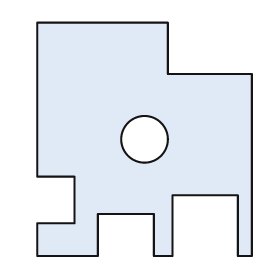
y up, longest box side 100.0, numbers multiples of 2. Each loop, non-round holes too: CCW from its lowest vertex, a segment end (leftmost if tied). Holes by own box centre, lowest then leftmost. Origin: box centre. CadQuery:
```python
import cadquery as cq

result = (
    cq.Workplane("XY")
    .moveTo(-46.0, -50.0)
    .lineTo(-20.0, -50.0)
    .lineTo(-20.0, -32.0)
    .lineTo(4.0, -32.0)
    .lineTo(4.0, -50.0)
    .lineTo(12.0, -50.0)
    .lineTo(12.0, -24.0)
    .lineTo(40.0, -24.0)
    .lineTo(40.0, -50.0)
    .lineTo(46.0, -50.0)
    .lineTo(46.0, 28.0)
    .lineTo(10.0, 28.0)
    .lineTo(10.0, 50.0)
    .lineTo(-46.0, 50.0)
    .lineTo(-46.0, -16.0)
    .lineTo(-30.0, -16.0)
    .lineTo(-30.0, -36.0)
    .lineTo(-46.0, -36.0)
    .close()
    .moveTo(0.0, 0.0)
    .circle(10.0)
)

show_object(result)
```